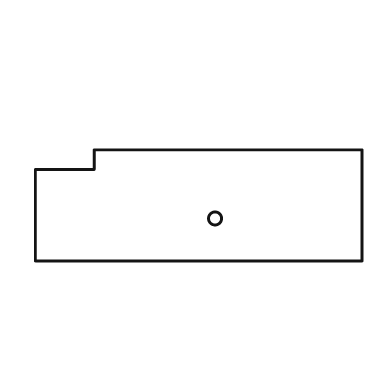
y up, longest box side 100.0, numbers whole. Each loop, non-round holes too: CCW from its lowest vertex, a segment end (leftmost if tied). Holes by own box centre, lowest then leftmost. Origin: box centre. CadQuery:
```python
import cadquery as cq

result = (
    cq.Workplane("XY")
    .moveTo(-50.0, -17.0)
    .lineTo(50.0, -17.0)
    .lineTo(50.0, 17.0)
    .lineTo(-32.0, 17.0)
    .lineTo(-32.0, 11.0)
    .lineTo(-50.0, 11.0)
    .close()
    .moveTo(5.0, -4.0)
    .circle(2.0)
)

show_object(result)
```